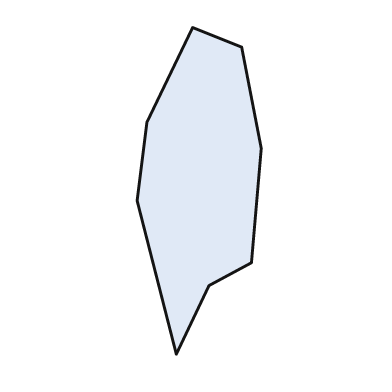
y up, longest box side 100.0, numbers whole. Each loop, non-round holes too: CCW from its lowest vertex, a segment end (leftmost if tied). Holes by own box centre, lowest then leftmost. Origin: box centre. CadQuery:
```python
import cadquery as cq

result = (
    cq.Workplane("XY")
    .moveTo(-7.0, -50.0)
    .lineTo(3.0, -29.0)
    .lineTo(16.0, -22.0)
    .lineTo(19.0, 13.0)
    .lineTo(13.0, 44.0)
    .lineTo(-2.0, 50.0)
    .lineTo(-16.0, 21.0)
    .lineTo(-19.0, -3.0)
    .close()
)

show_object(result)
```